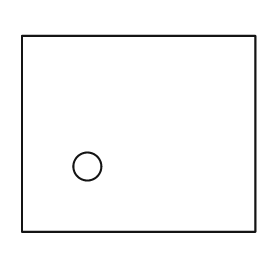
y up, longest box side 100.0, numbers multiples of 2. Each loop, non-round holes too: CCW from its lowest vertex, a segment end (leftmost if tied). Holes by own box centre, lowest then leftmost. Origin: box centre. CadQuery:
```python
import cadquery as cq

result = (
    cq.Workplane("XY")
    .moveTo(-50.0, -42.0)
    .lineTo(50.0, -42.0)
    .lineTo(50.0, 42.0)
    .lineTo(-50.0, 42.0)
    .close()
    .moveTo(-22.0, -14.0)
    .circle(6.0)
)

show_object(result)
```